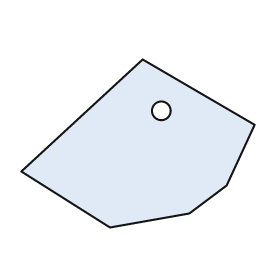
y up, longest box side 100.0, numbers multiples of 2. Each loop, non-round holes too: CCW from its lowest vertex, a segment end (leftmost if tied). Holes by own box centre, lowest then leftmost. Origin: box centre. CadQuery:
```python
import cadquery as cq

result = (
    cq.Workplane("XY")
    .moveTo(-12.0, -36.0)
    .lineTo(22.0, -30.0)
    .lineTo(38.0, -18.0)
    .lineTo(50.0, 8.0)
    .lineTo(2.0, 36.0)
    .lineTo(-50.0, -12.0)
    .close()
    .moveTo(10.0, 14.0)
    .circle(4.0)
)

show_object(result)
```